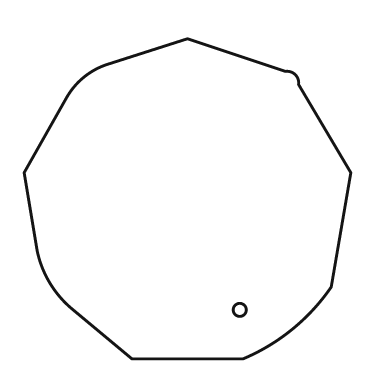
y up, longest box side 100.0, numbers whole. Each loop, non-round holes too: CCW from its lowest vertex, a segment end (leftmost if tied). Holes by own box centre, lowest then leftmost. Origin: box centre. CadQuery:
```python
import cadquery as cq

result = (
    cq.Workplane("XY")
    .moveTo(-17.0, -49.0)
    .lineTo(17.0, -49.0)
    .threePointArc((32.0, -40.0), (44.0, -27.0))
    .lineTo(50.0, 8.0)
    .lineTo(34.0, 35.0)
    .threePointArc((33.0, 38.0), (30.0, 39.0))
    .lineTo(0.0, 49.0)
    .lineTo(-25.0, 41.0)
    .threePointArc((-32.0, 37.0), (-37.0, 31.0))
    .lineTo(-50.0, 8.0)
    .lineTo(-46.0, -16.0)
    .threePointArc((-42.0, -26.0), (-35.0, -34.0))
    .close()
    .moveTo(16.0, -34.0)
    .circle(2.0)
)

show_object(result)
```